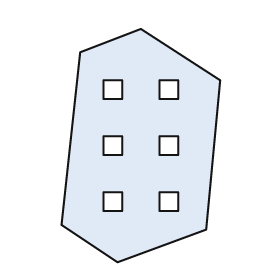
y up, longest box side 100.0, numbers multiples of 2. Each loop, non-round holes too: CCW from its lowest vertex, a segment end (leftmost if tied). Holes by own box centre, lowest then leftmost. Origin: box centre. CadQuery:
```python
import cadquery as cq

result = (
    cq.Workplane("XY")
    .moveTo(-10.0, -50.0)
    .lineTo(28.0, -36.0)
    .lineTo(34.0, 28.0)
    .lineTo(0.0, 50.0)
    .lineTo(-26.0, 40.0)
    .lineTo(-34.0, -34.0)
    .close()
    .moveTo(-16.0, -28.0)
    .lineTo(-8.0, -28.0)
    .lineTo(-8.0, -20.0)
    .lineTo(-16.0, -20.0)
    .close()
    .moveTo(8.0, -28.0)
    .lineTo(16.0, -28.0)
    .lineTo(16.0, -20.0)
    .lineTo(8.0, -20.0)
    .close()
    .moveTo(-16.0, -4.0)
    .lineTo(-8.0, -4.0)
    .lineTo(-8.0, 4.0)
    .lineTo(-16.0, 4.0)
    .close()
    .moveTo(8.0, -4.0)
    .lineTo(16.0, -4.0)
    .lineTo(16.0, 4.0)
    .lineTo(8.0, 4.0)
    .close()
    .moveTo(-16.0, 20.0)
    .lineTo(-8.0, 20.0)
    .lineTo(-8.0, 28.0)
    .lineTo(-16.0, 28.0)
    .close()
    .moveTo(8.0, 20.0)
    .lineTo(16.0, 20.0)
    .lineTo(16.0, 28.0)
    .lineTo(8.0, 28.0)
    .close()
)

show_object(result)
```